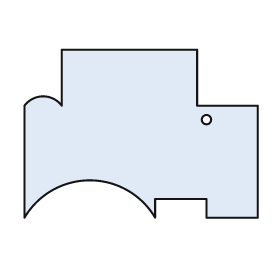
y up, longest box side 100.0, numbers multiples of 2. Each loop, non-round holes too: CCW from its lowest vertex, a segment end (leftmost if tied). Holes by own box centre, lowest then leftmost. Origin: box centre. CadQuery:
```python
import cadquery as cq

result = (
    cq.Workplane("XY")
    .moveTo(-50.0, -36.0)
    .threePointArc((-22.0, -20.0), (6.0, -36.0))
    .lineTo(6.0, -28.0)
    .lineTo(28.0, -28.0)
    .lineTo(28.0, -36.0)
    .lineTo(50.0, -36.0)
    .lineTo(50.0, 12.0)
    .lineTo(24.0, 12.0)
    .lineTo(24.0, 36.0)
    .lineTo(-34.0, 36.0)
    .lineTo(-34.0, 12.0)
    .threePointArc((-42.0, 16.0), (-50.0, 12.0))
    .close()
    .moveTo(28.0, 6.0)
    .circle(2.0)
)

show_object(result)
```